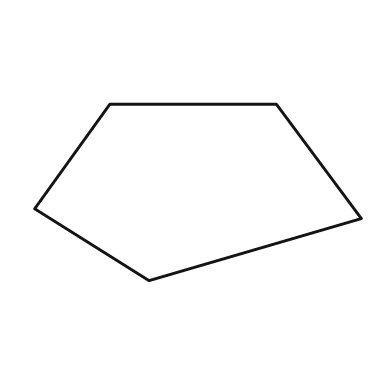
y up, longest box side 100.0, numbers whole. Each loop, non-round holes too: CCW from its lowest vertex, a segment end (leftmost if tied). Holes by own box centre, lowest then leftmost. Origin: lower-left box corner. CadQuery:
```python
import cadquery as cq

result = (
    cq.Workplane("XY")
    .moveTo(35.0, 0.0)
    .lineTo(100.0, 19.0)
    .lineTo(74.0, 54.0)
    .lineTo(23.0, 54.0)
    .lineTo(0.0, 22.0)
    .close()
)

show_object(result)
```